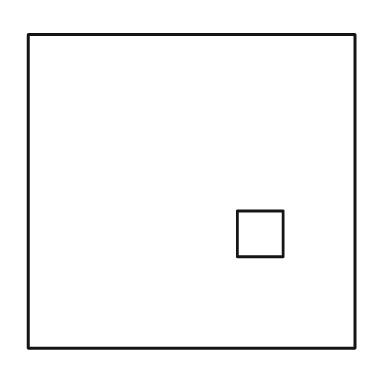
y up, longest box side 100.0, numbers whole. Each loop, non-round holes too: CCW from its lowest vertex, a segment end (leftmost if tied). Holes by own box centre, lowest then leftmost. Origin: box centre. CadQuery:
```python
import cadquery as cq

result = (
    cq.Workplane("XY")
    .moveTo(-50.0, -48.0)
    .lineTo(50.0, -48.0)
    .lineTo(50.0, 48.0)
    .lineTo(-50.0, 48.0)
    .close()
    .moveTo(14.0, -20.0)
    .lineTo(28.0, -20.0)
    .lineTo(28.0, -6.0)
    .lineTo(14.0, -6.0)
    .close()
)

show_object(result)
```